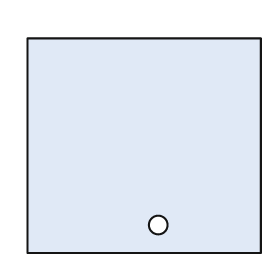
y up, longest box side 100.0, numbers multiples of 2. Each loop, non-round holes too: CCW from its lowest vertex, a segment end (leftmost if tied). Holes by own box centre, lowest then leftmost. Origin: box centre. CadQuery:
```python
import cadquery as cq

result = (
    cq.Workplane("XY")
    .moveTo(-50.0, -46.0)
    .lineTo(50.0, -46.0)
    .lineTo(50.0, 46.0)
    .lineTo(-50.0, 46.0)
    .close()
    .moveTo(6.0, -34.0)
    .circle(4.0)
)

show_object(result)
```